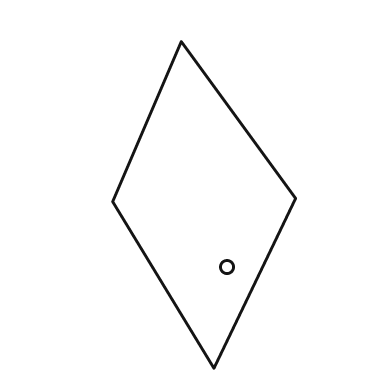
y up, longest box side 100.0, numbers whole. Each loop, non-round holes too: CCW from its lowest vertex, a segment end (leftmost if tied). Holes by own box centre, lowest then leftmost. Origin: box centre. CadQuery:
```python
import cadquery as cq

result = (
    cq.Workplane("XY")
    .moveTo(3.0, -50.0)
    .lineTo(28.0, 2.0)
    .lineTo(-7.0, 50.0)
    .lineTo(-28.0, 1.0)
    .close()
    .moveTo(7.0, -19.0)
    .circle(2.0)
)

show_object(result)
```